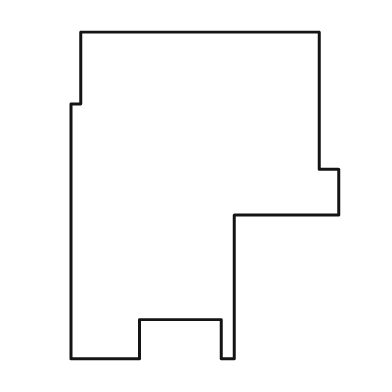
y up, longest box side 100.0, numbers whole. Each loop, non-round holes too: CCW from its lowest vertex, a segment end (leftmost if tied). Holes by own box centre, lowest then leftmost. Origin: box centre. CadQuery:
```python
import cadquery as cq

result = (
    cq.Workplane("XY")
    .moveTo(-41.0, -50.0)
    .lineTo(-20.0, -50.0)
    .lineTo(-20.0, -38.0)
    .lineTo(5.0, -38.0)
    .lineTo(5.0, -50.0)
    .lineTo(9.0, -50.0)
    .lineTo(9.0, -6.0)
    .lineTo(41.0, -6.0)
    .lineTo(41.0, 8.0)
    .lineTo(35.0, 8.0)
    .lineTo(35.0, 50.0)
    .lineTo(-38.0, 50.0)
    .lineTo(-38.0, 28.0)
    .lineTo(-41.0, 28.0)
    .close()
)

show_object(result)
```